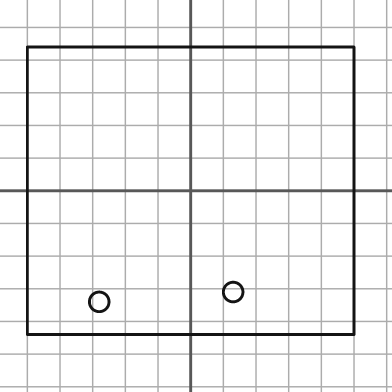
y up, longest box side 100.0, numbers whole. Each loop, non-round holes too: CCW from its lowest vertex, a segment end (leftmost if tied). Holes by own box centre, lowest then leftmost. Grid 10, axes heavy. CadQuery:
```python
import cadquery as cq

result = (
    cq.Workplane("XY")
    .moveTo(-50.0, -44.0)
    .lineTo(50.0, -44.0)
    .lineTo(50.0, 44.0)
    .lineTo(-50.0, 44.0)
    .close()
    .moveTo(-28.0, -34.0)
    .circle(3.0)
    .moveTo(13.0, -31.0)
    .circle(3.0)
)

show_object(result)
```